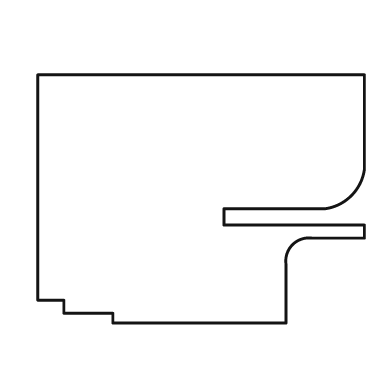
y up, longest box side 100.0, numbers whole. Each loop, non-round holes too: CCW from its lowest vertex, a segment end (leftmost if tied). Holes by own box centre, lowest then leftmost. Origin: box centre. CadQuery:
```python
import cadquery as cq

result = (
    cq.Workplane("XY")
    .moveTo(-27.0, -38.0)
    .lineTo(26.0, -38.0)
    .lineTo(26.0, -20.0)
    .threePointArc((28.0, -14.0), (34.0, -12.0))
    .lineTo(50.0, -12.0)
    .lineTo(50.0, -8.0)
    .lineTo(7.0, -8.0)
    .lineTo(7.0, -3.0)
    .lineTo(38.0, -3.0)
    .threePointArc((46.0, 1.0), (50.0, 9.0))
    .lineTo(50.0, 38.0)
    .lineTo(-50.0, 38.0)
    .lineTo(-50.0, -31.0)
    .lineTo(-42.0, -31.0)
    .lineTo(-42.0, -35.0)
    .lineTo(-27.0, -35.0)
    .close()
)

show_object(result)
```